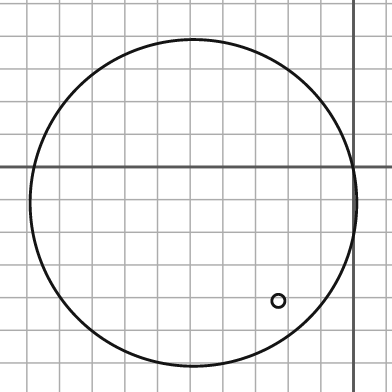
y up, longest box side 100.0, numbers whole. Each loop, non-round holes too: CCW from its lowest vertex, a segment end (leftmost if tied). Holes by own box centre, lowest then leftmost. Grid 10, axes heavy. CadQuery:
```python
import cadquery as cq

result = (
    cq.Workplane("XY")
    .moveTo(-49.0, -11.0)
    .circle(50.0)
    .moveTo(-23.0, -41.0)
    .circle(2.0)
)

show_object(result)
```